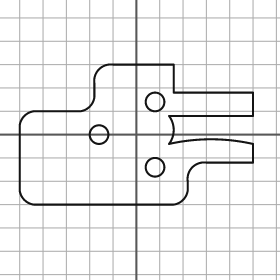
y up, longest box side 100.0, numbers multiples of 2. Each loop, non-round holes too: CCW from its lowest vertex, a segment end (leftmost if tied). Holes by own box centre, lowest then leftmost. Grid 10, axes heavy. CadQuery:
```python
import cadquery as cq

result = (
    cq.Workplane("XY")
    .moveTo(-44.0, -30.0)
    .lineTo(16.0, -30.0)
    .threePointArc((20.0, -28.0), (22.0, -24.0))
    .lineTo(22.0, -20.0)
    .threePointArc((24.0, -14.0), (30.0, -12.0))
    .lineTo(50.0, -12.0)
    .lineTo(50.0, -4.0)
    .threePointArc((32.0, -2.0), (14.0, -4.0))
    .threePointArc((16.0, 2.0), (14.0, 8.0))
    .lineTo(50.0, 8.0)
    .lineTo(50.0, 18.0)
    .lineTo(16.0, 18.0)
    .lineTo(16.0, 30.0)
    .lineTo(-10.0, 30.0)
    .threePointArc((-16.0, 28.0), (-18.0, 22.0))
    .lineTo(-18.0, 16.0)
    .threePointArc((-20.0, 12.0), (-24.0, 10.0))
    .lineTo(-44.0, 10.0)
    .threePointArc((-48.0, 8.0), (-50.0, 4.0))
    .lineTo(-50.0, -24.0)
    .threePointArc((-48.0, -28.0), (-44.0, -30.0))
    .close()
    .moveTo(8.0, -14.0)
    .circle(4.0)
    .moveTo(-16.0, 0.0)
    .circle(4.0)
    .moveTo(8.0, 14.0)
    .circle(4.0)
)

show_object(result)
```